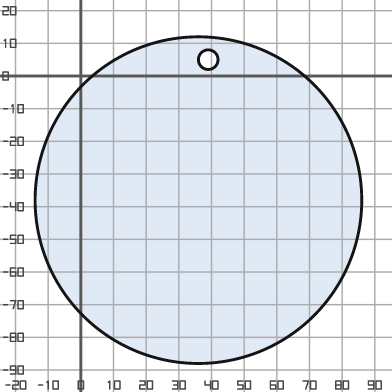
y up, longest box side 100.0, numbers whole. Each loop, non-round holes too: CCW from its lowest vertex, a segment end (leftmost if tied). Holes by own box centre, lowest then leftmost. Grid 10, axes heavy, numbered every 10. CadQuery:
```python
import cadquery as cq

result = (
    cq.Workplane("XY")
    .moveTo(36.0, -38.0)
    .circle(50.0)
    .moveTo(39.0, 5.0)
    .circle(3.0)
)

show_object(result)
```